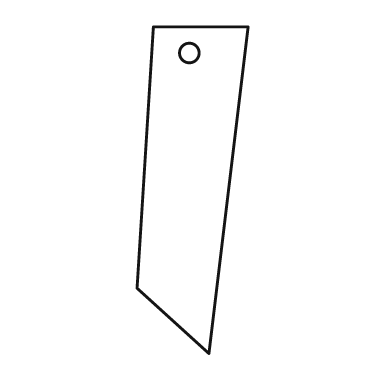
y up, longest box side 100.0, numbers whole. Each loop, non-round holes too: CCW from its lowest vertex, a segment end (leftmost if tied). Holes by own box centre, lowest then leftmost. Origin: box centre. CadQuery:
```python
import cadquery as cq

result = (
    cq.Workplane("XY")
    .moveTo(5.0, -50.0)
    .lineTo(17.0, 50.0)
    .lineTo(-12.0, 50.0)
    .lineTo(-17.0, -30.0)
    .close()
    .moveTo(-1.0, 42.0)
    .circle(3.0)
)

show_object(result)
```